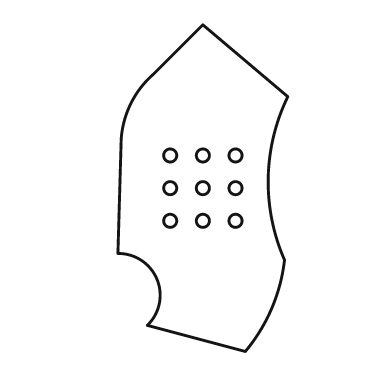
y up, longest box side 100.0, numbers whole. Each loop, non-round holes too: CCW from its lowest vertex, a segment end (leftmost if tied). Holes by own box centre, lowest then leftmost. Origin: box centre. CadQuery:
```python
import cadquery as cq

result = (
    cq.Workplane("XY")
    .moveTo(13.0, -50.0)
    .threePointArc((21.0, -37.0), (25.0, -22.0))
    .threePointArc((20.0, 3.0), (26.0, 28.0))
    .lineTo(0.0, 50.0)
    .lineTo(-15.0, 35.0)
    .threePointArc((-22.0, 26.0), (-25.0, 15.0))
    .lineTo(-26.0, -20.0)
    .threePointArc((-14.0, -28.0), (-17.0, -42.0))
    .close()
    .moveTo(-10.0, -10.0)
    .circle(2.0)
    .moveTo(0.0, -10.0)
    .circle(2.0)
    .moveTo(10.0, -10.0)
    .circle(2.0)
    .moveTo(-10.0, 0.0)
    .circle(2.0)
    .moveTo(0.0, 0.0)
    .circle(2.0)
    .moveTo(10.0, 0.0)
    .circle(2.0)
    .moveTo(-10.0, 10.0)
    .circle(2.0)
    .moveTo(0.0, 10.0)
    .circle(2.0)
    .moveTo(10.0, 10.0)
    .circle(2.0)
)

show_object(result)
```